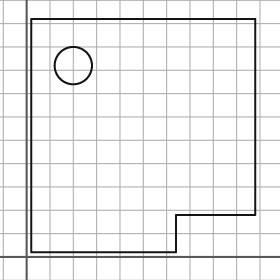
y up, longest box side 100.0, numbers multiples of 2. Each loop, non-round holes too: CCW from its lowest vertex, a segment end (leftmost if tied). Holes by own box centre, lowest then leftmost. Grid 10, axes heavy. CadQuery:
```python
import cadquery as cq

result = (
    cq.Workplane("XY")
    .moveTo(2.0, 2.0)
    .lineTo(64.0, 2.0)
    .lineTo(64.0, 18.0)
    .lineTo(98.0, 18.0)
    .lineTo(98.0, 102.0)
    .lineTo(2.0, 102.0)
    .close()
    .moveTo(20.0, 82.0)
    .circle(8.0)
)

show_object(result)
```